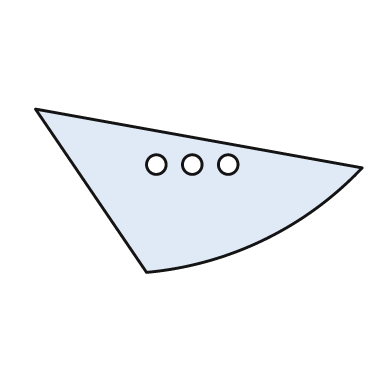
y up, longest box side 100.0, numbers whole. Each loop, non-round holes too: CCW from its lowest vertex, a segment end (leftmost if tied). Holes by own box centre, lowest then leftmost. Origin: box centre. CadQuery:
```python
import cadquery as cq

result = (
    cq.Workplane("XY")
    .moveTo(-16.0, -25.0)
    .threePointArc((20.0, -15.0), (50.0, 7.0))
    .lineTo(-50.0, 25.0)
    .close()
    .moveTo(-13.0, 8.0)
    .circle(3.0)
    .moveTo(-2.0, 8.0)
    .circle(3.0)
    .moveTo(9.0, 8.0)
    .circle(3.0)
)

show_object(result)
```